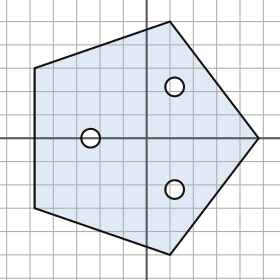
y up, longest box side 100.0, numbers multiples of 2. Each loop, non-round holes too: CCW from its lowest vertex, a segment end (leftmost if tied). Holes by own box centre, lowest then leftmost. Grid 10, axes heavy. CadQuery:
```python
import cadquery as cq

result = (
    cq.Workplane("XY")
    .moveTo(10.0, -50.0)
    .lineTo(48.0, 0.0)
    .lineTo(10.0, 50.0)
    .lineTo(-48.0, 30.0)
    .lineTo(-48.0, -30.0)
    .close()
    .moveTo(12.0, -22.0)
    .circle(4.0)
    .moveTo(-24.0, 0.0)
    .circle(4.0)
    .moveTo(12.0, 22.0)
    .circle(4.0)
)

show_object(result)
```